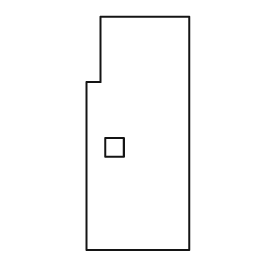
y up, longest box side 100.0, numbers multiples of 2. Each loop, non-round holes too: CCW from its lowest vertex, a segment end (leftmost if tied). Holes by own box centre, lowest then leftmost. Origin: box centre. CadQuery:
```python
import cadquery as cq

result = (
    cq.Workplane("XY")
    .moveTo(-22.0, -50.0)
    .lineTo(22.0, -50.0)
    .lineTo(22.0, 50.0)
    .lineTo(-16.0, 50.0)
    .lineTo(-16.0, 22.0)
    .lineTo(-22.0, 22.0)
    .close()
    .moveTo(-14.0, -10.0)
    .lineTo(-6.0, -10.0)
    .lineTo(-6.0, -2.0)
    .lineTo(-14.0, -2.0)
    .close()
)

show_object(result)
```